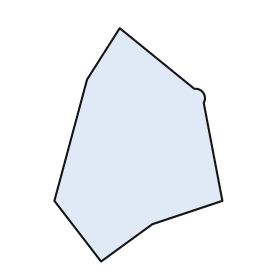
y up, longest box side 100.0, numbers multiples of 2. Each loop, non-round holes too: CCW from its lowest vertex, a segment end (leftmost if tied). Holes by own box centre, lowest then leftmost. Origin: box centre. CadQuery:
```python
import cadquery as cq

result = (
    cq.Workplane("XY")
    .moveTo(-16.0, -50.0)
    .lineTo(6.0, -34.0)
    .lineTo(36.0, -24.0)
    .lineTo(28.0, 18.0)
    .threePointArc((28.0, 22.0), (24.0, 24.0))
    .lineTo(-8.0, 50.0)
    .lineTo(-22.0, 28.0)
    .lineTo(-36.0, -24.0)
    .close()
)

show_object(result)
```